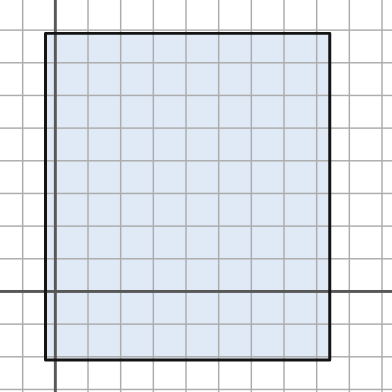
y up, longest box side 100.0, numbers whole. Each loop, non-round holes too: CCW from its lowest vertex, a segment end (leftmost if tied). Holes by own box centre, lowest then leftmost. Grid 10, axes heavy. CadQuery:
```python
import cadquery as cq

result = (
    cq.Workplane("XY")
    .moveTo(-3.0, -21.0)
    .lineTo(84.0, -21.0)
    .lineTo(84.0, 79.0)
    .lineTo(-3.0, 79.0)
    .close()
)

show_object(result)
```